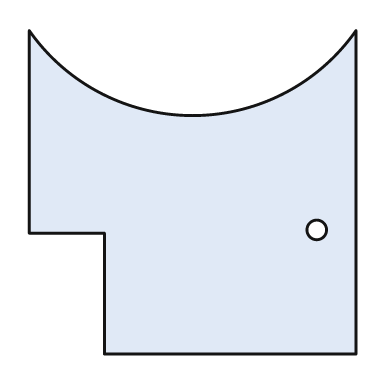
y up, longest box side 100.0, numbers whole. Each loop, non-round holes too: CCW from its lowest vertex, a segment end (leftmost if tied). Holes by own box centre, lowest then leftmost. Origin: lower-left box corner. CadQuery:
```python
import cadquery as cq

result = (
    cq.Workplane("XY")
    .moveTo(23.0, 0.0)
    .lineTo(100.0, 0.0)
    .lineTo(100.0, 99.0)
    .threePointArc((50.0, 73.0), (0.0, 99.0))
    .lineTo(0.0, 37.0)
    .lineTo(23.0, 37.0)
    .close()
    .moveTo(88.0, 38.0)
    .circle(3.0)
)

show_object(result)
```